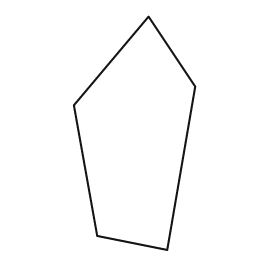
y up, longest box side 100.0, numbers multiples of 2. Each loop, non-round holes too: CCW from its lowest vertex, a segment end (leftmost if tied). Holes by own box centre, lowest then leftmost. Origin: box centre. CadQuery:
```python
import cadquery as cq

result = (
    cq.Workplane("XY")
    .moveTo(14.0, -50.0)
    .lineTo(26.0, 20.0)
    .lineTo(6.0, 50.0)
    .lineTo(-26.0, 12.0)
    .lineTo(-16.0, -44.0)
    .close()
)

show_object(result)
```